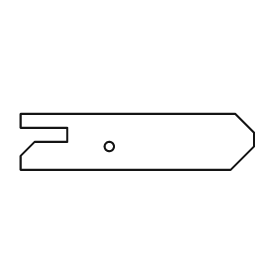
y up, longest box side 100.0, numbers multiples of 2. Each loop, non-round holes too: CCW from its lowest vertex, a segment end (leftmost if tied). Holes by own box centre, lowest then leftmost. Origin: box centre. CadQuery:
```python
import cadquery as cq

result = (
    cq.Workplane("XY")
    .moveTo(-50.0, -12.0)
    .lineTo(40.0, -12.0)
    .lineTo(50.0, -2.0)
    .lineTo(50.0, 4.0)
    .lineTo(42.0, 12.0)
    .lineTo(-50.0, 12.0)
    .lineTo(-50.0, 6.0)
    .lineTo(-30.0, 6.0)
    .lineTo(-30.0, 0.0)
    .lineTo(-44.0, 0.0)
    .lineTo(-50.0, -6.0)
    .close()
    .moveTo(-12.0, -2.0)
    .circle(2.0)
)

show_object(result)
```